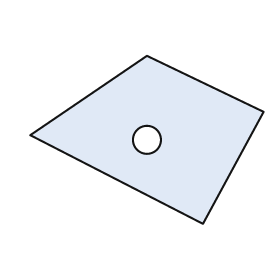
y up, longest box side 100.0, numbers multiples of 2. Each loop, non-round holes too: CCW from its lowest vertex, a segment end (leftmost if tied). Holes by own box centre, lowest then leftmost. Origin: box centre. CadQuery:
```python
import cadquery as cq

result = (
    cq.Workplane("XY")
    .moveTo(24.0, -36.0)
    .lineTo(50.0, 12.0)
    .lineTo(0.0, 36.0)
    .lineTo(-50.0, 2.0)
    .close()
    .moveTo(0.0, 0.0)
    .circle(6.0)
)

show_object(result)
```